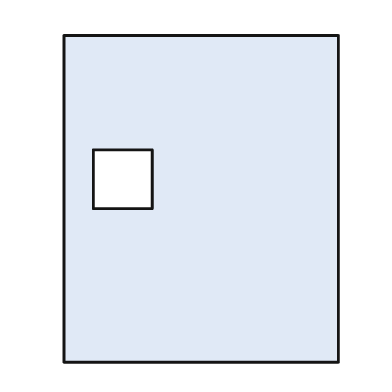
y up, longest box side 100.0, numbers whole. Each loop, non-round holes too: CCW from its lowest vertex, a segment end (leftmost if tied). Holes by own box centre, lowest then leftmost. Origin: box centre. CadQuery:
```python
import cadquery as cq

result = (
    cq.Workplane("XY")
    .moveTo(-42.0, -50.0)
    .lineTo(42.0, -50.0)
    .lineTo(42.0, 50.0)
    .lineTo(-42.0, 50.0)
    .close()
    .moveTo(-33.0, -3.0)
    .lineTo(-15.0, -3.0)
    .lineTo(-15.0, 15.0)
    .lineTo(-33.0, 15.0)
    .close()
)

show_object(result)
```